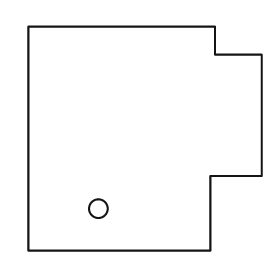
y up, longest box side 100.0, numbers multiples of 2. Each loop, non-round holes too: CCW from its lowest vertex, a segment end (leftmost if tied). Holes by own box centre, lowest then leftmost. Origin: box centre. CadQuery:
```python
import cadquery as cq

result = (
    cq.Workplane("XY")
    .moveTo(-50.0, -48.0)
    .lineTo(28.0, -48.0)
    .lineTo(28.0, -16.0)
    .lineTo(50.0, -16.0)
    .lineTo(50.0, 36.0)
    .lineTo(30.0, 36.0)
    .lineTo(30.0, 48.0)
    .lineTo(-50.0, 48.0)
    .close()
    .moveTo(-20.0, -30.0)
    .circle(4.0)
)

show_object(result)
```